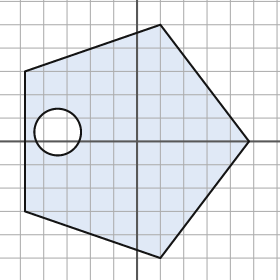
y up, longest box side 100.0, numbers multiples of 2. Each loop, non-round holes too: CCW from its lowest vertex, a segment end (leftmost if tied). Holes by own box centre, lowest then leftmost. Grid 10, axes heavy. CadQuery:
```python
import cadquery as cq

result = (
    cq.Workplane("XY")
    .moveTo(10.0, -50.0)
    .lineTo(48.0, 0.0)
    .lineTo(10.0, 50.0)
    .lineTo(-48.0, 30.0)
    .lineTo(-48.0, -30.0)
    .close()
    .moveTo(-34.0, 4.0)
    .circle(10.0)
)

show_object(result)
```